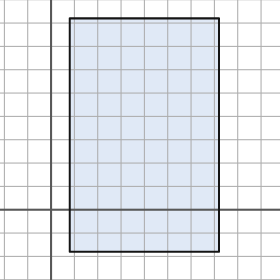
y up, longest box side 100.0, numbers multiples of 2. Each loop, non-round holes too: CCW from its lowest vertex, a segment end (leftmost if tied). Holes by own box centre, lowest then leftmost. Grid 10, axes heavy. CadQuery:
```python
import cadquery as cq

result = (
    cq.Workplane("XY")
    .moveTo(8.0, -18.0)
    .lineTo(72.0, -18.0)
    .lineTo(72.0, 82.0)
    .lineTo(8.0, 82.0)
    .close()
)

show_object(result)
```